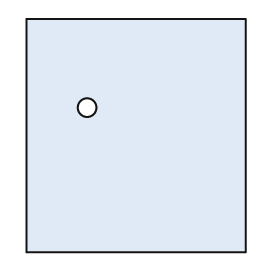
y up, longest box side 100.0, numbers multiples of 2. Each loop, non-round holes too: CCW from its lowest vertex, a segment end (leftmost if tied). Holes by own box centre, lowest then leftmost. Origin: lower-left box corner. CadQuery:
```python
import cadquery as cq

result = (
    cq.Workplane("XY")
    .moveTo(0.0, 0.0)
    .lineTo(94.0, 0.0)
    .lineTo(94.0, 100.0)
    .lineTo(0.0, 100.0)
    .close()
    .moveTo(26.0, 62.0)
    .circle(4.0)
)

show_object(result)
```